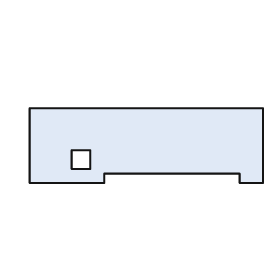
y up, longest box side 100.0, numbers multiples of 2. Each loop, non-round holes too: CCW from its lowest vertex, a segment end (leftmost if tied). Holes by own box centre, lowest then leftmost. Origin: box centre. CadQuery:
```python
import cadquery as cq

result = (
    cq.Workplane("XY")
    .moveTo(-50.0, -16.0)
    .lineTo(-18.0, -16.0)
    .lineTo(-18.0, -12.0)
    .lineTo(40.0, -12.0)
    .lineTo(40.0, -16.0)
    .lineTo(50.0, -16.0)
    .lineTo(50.0, 16.0)
    .lineTo(-50.0, 16.0)
    .close()
    .moveTo(-32.0, -10.0)
    .lineTo(-24.0, -10.0)
    .lineTo(-24.0, -2.0)
    .lineTo(-32.0, -2.0)
    .close()
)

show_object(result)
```